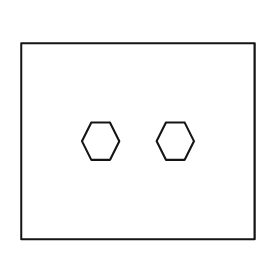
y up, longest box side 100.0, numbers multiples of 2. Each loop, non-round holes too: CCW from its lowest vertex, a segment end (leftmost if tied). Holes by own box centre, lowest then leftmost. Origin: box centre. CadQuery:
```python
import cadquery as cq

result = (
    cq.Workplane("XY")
    .moveTo(-50.0, -42.0)
    .lineTo(50.0, -42.0)
    .lineTo(50.0, 42.0)
    .lineTo(-50.0, 42.0)
    .close()
    .moveTo(-20.0, -8.0)
    .lineTo(-12.0, -8.0)
    .lineTo(-8.0, 0.0)
    .lineTo(-12.0, 8.0)
    .lineTo(-20.0, 8.0)
    .lineTo(-24.0, 0.0)
    .close()
    .moveTo(12.0, -8.0)
    .lineTo(20.0, -8.0)
    .lineTo(24.0, 0.0)
    .lineTo(20.0, 8.0)
    .lineTo(12.0, 8.0)
    .lineTo(8.0, 0.0)
    .close()
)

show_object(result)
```